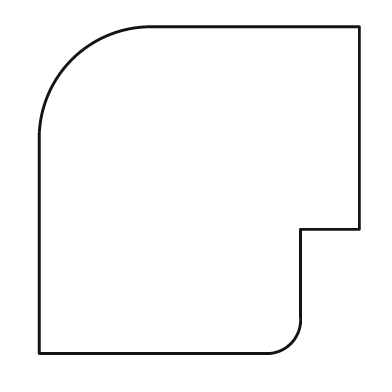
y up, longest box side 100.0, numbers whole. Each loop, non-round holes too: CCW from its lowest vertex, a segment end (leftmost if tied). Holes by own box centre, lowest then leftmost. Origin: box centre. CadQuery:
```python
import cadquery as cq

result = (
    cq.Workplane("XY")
    .moveTo(-49.0, -50.0)
    .lineTo(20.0, -50.0)
    .threePointArc((28.0, -47.0), (31.0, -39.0))
    .lineTo(31.0, -12.0)
    .lineTo(49.0, -12.0)
    .lineTo(49.0, 50.0)
    .lineTo(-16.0, 50.0)
    .threePointArc((-39.0, 40.0), (-49.0, 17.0))
    .close()
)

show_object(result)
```